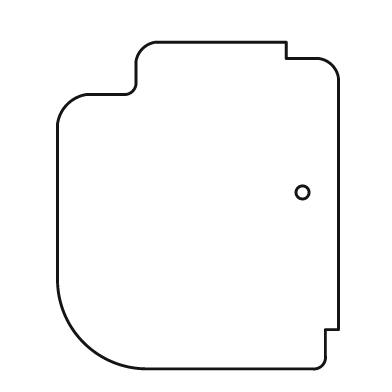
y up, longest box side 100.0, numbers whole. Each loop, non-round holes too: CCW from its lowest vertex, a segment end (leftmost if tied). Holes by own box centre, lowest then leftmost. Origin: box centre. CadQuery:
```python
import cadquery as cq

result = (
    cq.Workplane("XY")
    .moveTo(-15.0, -50.0)
    .lineTo(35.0, -50.0)
    .threePointArc((38.0, -49.0), (39.0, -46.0))
    .lineTo(39.0, -38.0)
    .lineTo(43.0, -38.0)
    .lineTo(43.0, 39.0)
    .threePointArc((41.0, 43.0), (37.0, 45.0))
    .lineTo(27.0, 45.0)
    .lineTo(27.0, 50.0)
    .lineTo(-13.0, 50.0)
    .threePointArc((-17.0, 48.0), (-19.0, 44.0))
    .lineTo(-19.0, 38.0)
    .threePointArc((-20.0, 35.0), (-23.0, 34.0))
    .lineTo(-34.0, 34.0)
    .threePointArc((-40.0, 31.0), (-43.0, 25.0))
    .lineTo(-43.0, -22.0)
    .threePointArc((-35.0, -42.0), (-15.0, -50.0))
    .close()
    .moveTo(32.0, 4.0)
    .circle(2.0)
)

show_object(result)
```